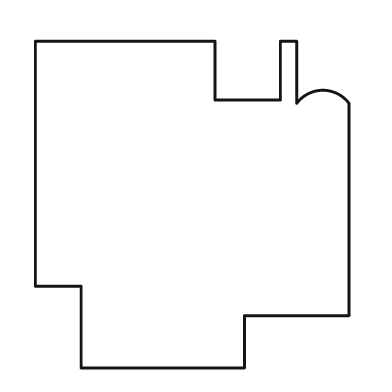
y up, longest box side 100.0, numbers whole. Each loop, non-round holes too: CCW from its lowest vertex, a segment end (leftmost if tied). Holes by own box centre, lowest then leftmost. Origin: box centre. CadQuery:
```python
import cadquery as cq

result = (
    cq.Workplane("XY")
    .moveTo(-34.0, -50.0)
    .lineTo(16.0, -50.0)
    .lineTo(16.0, -34.0)
    .lineTo(48.0, -34.0)
    .lineTo(48.0, 31.0)
    .threePointArc((40.0, 35.0), (32.0, 31.0))
    .lineTo(32.0, 50.0)
    .lineTo(27.0, 50.0)
    .lineTo(27.0, 32.0)
    .lineTo(7.0, 32.0)
    .lineTo(7.0, 50.0)
    .lineTo(-48.0, 50.0)
    .lineTo(-48.0, -25.0)
    .lineTo(-34.0, -25.0)
    .close()
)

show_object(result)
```